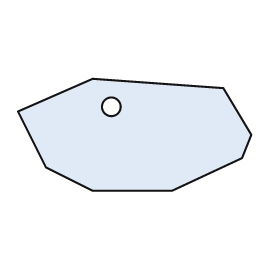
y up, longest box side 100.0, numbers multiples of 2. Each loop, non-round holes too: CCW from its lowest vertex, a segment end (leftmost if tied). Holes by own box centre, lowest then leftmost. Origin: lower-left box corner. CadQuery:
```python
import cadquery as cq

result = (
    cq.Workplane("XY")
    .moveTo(32.0, 0.0)
    .lineTo(66.0, 0.0)
    .lineTo(96.0, 14.0)
    .lineTo(100.0, 24.0)
    .lineTo(88.0, 44.0)
    .lineTo(32.0, 48.0)
    .lineTo(0.0, 34.0)
    .lineTo(12.0, 10.0)
    .close()
    .moveTo(40.0, 36.0)
    .circle(4.0)
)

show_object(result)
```